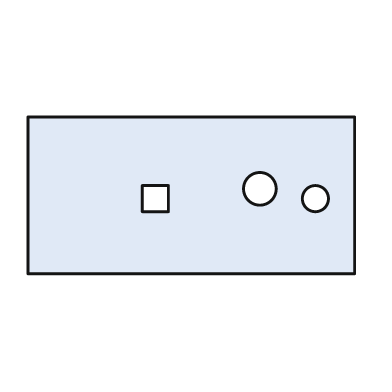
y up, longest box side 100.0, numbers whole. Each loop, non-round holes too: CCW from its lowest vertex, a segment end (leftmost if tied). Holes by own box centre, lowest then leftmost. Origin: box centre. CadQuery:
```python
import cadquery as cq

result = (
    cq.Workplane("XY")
    .moveTo(-50.0, -24.0)
    .lineTo(50.0, -24.0)
    .lineTo(50.0, 24.0)
    .lineTo(-50.0, 24.0)
    .close()
    .moveTo(-15.0, -5.0)
    .lineTo(-7.0, -5.0)
    .lineTo(-7.0, 3.0)
    .lineTo(-15.0, 3.0)
    .close()
    .moveTo(38.0, -1.0)
    .circle(4.0)
    .moveTo(21.0, 2.0)
    .circle(5.0)
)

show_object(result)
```